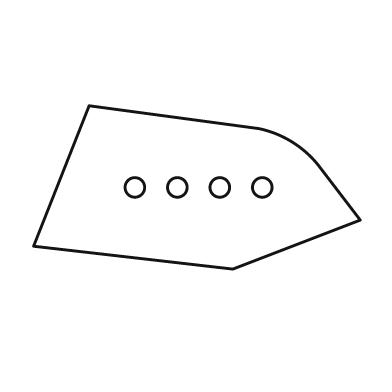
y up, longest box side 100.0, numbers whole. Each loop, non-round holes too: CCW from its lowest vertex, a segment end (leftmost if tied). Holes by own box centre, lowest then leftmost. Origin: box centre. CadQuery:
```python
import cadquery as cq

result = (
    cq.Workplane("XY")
    .moveTo(11.0, -25.0)
    .lineTo(50.0, -10.0)
    .lineTo(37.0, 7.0)
    .threePointArc((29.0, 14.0), (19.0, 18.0))
    .lineTo(-33.0, 25.0)
    .lineTo(-50.0, -18.0)
    .close()
    .moveTo(-19.0, 0.0)
    .circle(3.0)
    .moveTo(-6.0, 0.0)
    .circle(3.0)
    .moveTo(7.0, 0.0)
    .circle(3.0)
    .moveTo(20.0, 0.0)
    .circle(3.0)
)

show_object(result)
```